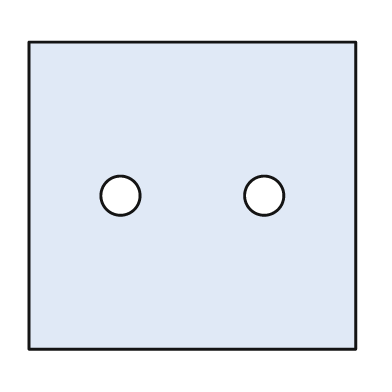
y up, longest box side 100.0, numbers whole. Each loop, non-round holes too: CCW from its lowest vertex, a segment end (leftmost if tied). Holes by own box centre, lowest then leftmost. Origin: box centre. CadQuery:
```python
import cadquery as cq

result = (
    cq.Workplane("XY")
    .moveTo(-50.0, -47.0)
    .lineTo(50.0, -47.0)
    .lineTo(50.0, 47.0)
    .lineTo(-50.0, 47.0)
    .close()
    .moveTo(-22.0, 0.0)
    .circle(6.0)
    .moveTo(22.0, 0.0)
    .circle(6.0)
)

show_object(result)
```